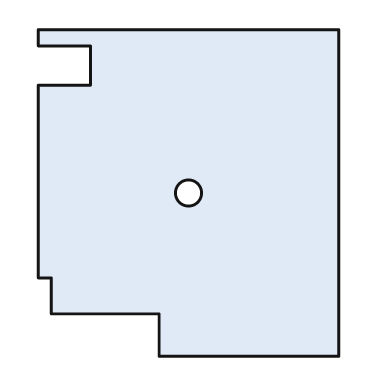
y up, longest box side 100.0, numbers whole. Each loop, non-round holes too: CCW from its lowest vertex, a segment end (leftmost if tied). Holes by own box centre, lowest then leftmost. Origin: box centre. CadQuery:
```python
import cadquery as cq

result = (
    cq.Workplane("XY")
    .moveTo(-9.0, -50.0)
    .lineTo(46.0, -50.0)
    .lineTo(46.0, 50.0)
    .lineTo(-46.0, 50.0)
    .lineTo(-46.0, 45.0)
    .lineTo(-30.0, 45.0)
    .lineTo(-30.0, 33.0)
    .lineTo(-46.0, 33.0)
    .lineTo(-46.0, -26.0)
    .lineTo(-42.0, -26.0)
    .lineTo(-42.0, -37.0)
    .lineTo(-9.0, -37.0)
    .close()
    .moveTo(0.0, 0.0)
    .circle(4.0)
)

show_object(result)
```